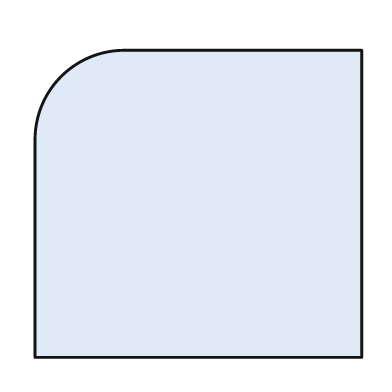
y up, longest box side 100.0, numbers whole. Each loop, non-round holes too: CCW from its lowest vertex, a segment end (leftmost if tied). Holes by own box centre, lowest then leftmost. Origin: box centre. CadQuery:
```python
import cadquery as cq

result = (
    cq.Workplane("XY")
    .moveTo(-50.0, -47.0)
    .lineTo(50.0, -47.0)
    .lineTo(50.0, 47.0)
    .lineTo(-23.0, 47.0)
    .threePointArc((-42.0, 39.0), (-50.0, 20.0))
    .close()
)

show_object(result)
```